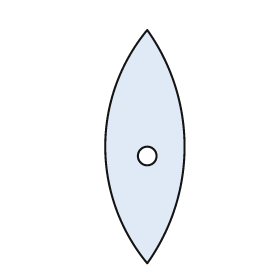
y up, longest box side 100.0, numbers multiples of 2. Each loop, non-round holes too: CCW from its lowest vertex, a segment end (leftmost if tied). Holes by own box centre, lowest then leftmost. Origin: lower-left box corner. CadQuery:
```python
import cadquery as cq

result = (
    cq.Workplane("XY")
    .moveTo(18.0, 0.0)
    .threePointArc((34.0, 50.0), (18.0, 100.0))
    .threePointArc((0.0, 50.0), (18.0, 0.0))
    .close()
    .moveTo(18.0, 46.0)
    .circle(4.0)
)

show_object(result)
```